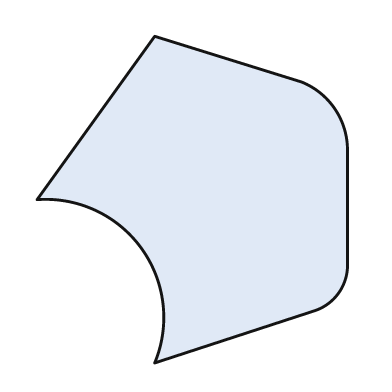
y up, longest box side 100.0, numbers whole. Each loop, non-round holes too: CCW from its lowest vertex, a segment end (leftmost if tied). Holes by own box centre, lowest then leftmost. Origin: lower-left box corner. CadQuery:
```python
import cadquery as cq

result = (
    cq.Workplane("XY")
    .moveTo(36.0, 0.0)
    .lineTo(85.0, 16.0)
    .threePointArc((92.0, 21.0), (95.0, 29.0))
    .lineTo(95.0, 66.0)
    .threePointArc((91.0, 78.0), (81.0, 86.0))
    .lineTo(36.0, 100.0)
    .lineTo(0.0, 50.0)
    .threePointArc((32.0, 35.0), (36.0, 0.0))
    .close()
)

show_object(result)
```